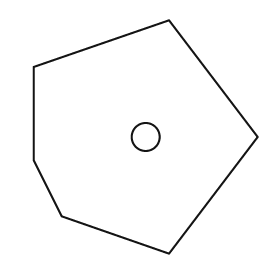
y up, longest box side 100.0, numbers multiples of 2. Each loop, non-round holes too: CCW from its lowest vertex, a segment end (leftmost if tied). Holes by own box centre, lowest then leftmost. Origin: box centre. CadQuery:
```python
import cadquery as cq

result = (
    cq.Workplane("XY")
    .moveTo(10.0, -50.0)
    .lineTo(48.0, 0.0)
    .lineTo(10.0, 50.0)
    .lineTo(-48.0, 30.0)
    .lineTo(-48.0, -10.0)
    .lineTo(-36.0, -34.0)
    .close()
    .moveTo(0.0, 0.0)
    .circle(6.0)
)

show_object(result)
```